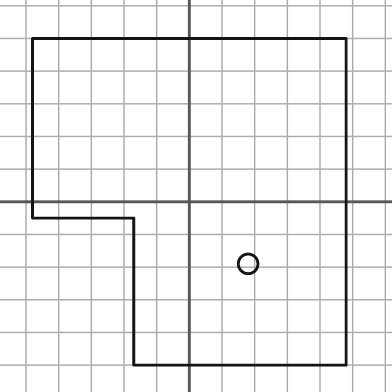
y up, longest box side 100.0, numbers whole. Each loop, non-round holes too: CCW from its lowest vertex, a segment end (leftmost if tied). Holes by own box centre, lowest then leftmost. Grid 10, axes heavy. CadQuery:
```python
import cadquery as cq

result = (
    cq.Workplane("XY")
    .moveTo(-17.0, -50.0)
    .lineTo(48.0, -50.0)
    .lineTo(48.0, 50.0)
    .lineTo(-48.0, 50.0)
    .lineTo(-48.0, -5.0)
    .lineTo(-17.0, -5.0)
    .close()
    .moveTo(18.0, -19.0)
    .circle(3.0)
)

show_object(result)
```